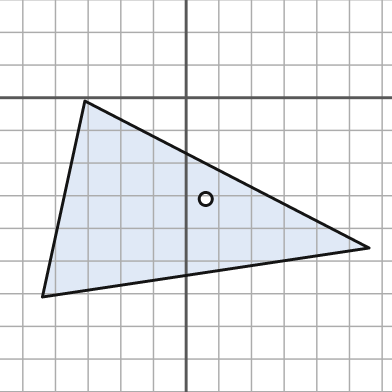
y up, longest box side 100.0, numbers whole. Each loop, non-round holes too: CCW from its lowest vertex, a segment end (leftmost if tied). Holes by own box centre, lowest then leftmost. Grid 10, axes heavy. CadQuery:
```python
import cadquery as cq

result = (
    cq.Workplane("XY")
    .moveTo(-44.0, -61.0)
    .lineTo(56.0, -46.0)
    .lineTo(-31.0, -1.0)
    .close()
    .moveTo(6.0, -31.0)
    .circle(2.0)
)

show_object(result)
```